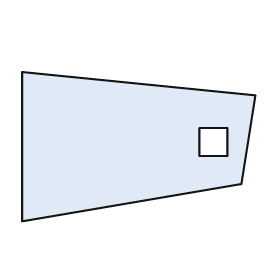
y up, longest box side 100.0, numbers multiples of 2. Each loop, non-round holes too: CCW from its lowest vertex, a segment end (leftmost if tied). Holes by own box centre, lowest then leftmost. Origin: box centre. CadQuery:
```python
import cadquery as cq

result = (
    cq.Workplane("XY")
    .moveTo(-50.0, -32.0)
    .lineTo(44.0, -16.0)
    .lineTo(50.0, 22.0)
    .lineTo(-50.0, 32.0)
    .close()
    .moveTo(26.0, -4.0)
    .lineTo(38.0, -4.0)
    .lineTo(38.0, 8.0)
    .lineTo(26.0, 8.0)
    .close()
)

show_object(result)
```